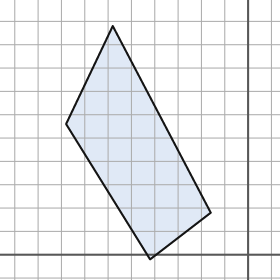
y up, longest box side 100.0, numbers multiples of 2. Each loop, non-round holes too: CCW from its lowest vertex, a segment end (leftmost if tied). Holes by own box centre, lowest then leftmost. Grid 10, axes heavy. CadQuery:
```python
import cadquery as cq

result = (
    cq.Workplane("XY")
    .moveTo(-42.0, -2.0)
    .lineTo(-16.0, 18.0)
    .lineTo(-58.0, 98.0)
    .lineTo(-78.0, 56.0)
    .close()
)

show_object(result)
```